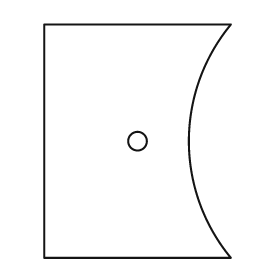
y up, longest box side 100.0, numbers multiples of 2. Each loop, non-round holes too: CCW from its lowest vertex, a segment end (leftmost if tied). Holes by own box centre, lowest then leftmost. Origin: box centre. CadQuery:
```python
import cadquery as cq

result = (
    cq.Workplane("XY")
    .moveTo(-40.0, -50.0)
    .lineTo(40.0, -50.0)
    .threePointArc((22.0, 0.0), (40.0, 50.0))
    .lineTo(-40.0, 50.0)
    .close()
    .moveTo(0.0, 0.0)
    .circle(4.0)
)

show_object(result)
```